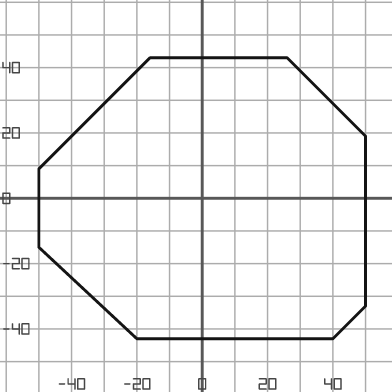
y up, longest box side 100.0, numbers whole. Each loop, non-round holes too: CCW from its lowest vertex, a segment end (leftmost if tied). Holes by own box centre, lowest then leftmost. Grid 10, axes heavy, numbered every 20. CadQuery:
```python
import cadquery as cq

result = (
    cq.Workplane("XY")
    .moveTo(-20.0, -43.0)
    .lineTo(40.0, -43.0)
    .lineTo(50.0, -33.0)
    .lineTo(50.0, 19.0)
    .lineTo(26.0, 43.0)
    .lineTo(-16.0, 43.0)
    .lineTo(-50.0, 9.0)
    .lineTo(-50.0, -15.0)
    .close()
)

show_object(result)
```